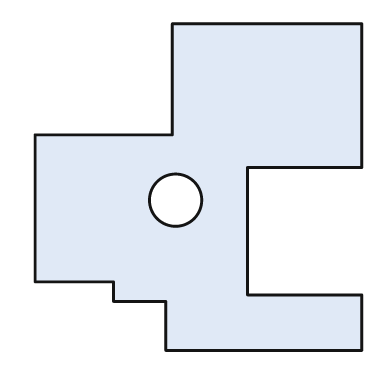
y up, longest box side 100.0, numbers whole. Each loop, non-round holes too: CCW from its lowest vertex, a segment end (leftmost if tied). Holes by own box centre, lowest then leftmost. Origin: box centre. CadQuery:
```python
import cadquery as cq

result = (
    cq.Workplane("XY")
    .moveTo(-10.0, -50.0)
    .lineTo(50.0, -50.0)
    .lineTo(50.0, -33.0)
    .lineTo(15.0, -33.0)
    .lineTo(15.0, 6.0)
    .lineTo(50.0, 6.0)
    .lineTo(50.0, 50.0)
    .lineTo(-8.0, 50.0)
    .lineTo(-8.0, 16.0)
    .lineTo(-50.0, 16.0)
    .lineTo(-50.0, -29.0)
    .lineTo(-26.0, -29.0)
    .lineTo(-26.0, -35.0)
    .lineTo(-10.0, -35.0)
    .close()
    .moveTo(-7.0, -4.0)
    .circle(8.0)
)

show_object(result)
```